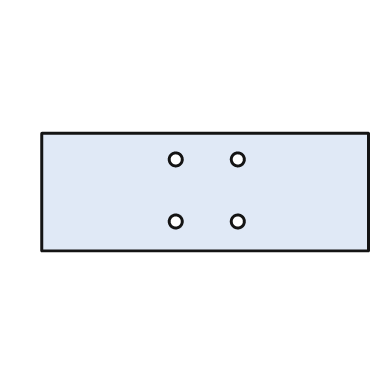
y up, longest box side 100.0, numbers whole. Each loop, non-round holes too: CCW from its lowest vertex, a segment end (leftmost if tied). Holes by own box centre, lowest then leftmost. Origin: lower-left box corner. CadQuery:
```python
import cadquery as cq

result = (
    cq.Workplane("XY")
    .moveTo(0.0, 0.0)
    .lineTo(100.0, 0.0)
    .lineTo(100.0, 36.0)
    .lineTo(0.0, 36.0)
    .close()
    .moveTo(41.0, 9.0)
    .circle(2.0)
    .moveTo(60.0, 9.0)
    .circle(2.0)
    .moveTo(41.0, 28.0)
    .circle(2.0)
    .moveTo(60.0, 28.0)
    .circle(2.0)
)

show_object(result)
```